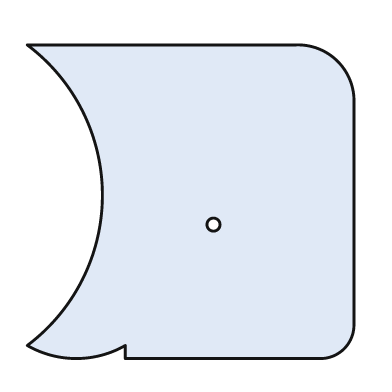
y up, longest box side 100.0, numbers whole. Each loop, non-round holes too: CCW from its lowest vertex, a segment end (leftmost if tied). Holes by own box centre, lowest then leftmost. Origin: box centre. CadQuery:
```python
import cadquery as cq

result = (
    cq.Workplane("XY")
    .moveTo(-20.0, -48.0)
    .lineTo(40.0, -48.0)
    .threePointArc((47.0, -45.0), (50.0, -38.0))
    .lineTo(50.0, 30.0)
    .threePointArc((45.0, 43.0), (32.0, 48.0))
    .lineTo(-50.0, 48.0)
    .threePointArc((-27.0, 2.0), (-50.0, -44.0))
    .threePointArc((-35.0, -48.0), (-20.0, -44.0))
    .close()
    .moveTo(7.0, -7.0)
    .circle(2.0)
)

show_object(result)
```